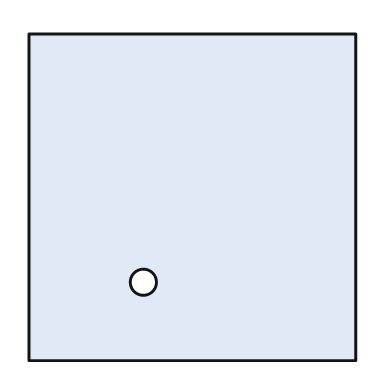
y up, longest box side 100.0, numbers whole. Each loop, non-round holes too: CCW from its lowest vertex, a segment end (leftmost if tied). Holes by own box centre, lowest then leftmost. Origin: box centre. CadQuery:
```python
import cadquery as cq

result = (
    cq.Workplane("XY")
    .moveTo(-50.0, -50.0)
    .lineTo(50.0, -50.0)
    .lineTo(50.0, 50.0)
    .lineTo(-50.0, 50.0)
    .close()
    .moveTo(-15.0, -26.0)
    .circle(4.0)
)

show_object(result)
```